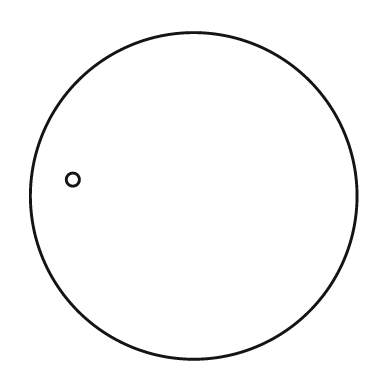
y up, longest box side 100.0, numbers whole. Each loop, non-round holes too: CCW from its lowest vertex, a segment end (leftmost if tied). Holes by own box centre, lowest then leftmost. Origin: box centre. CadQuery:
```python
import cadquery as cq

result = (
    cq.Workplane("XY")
    .moveTo(0.0, 0.0)
    .circle(50.0)
    .moveTo(-37.0, 5.0)
    .circle(2.0)
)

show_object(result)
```